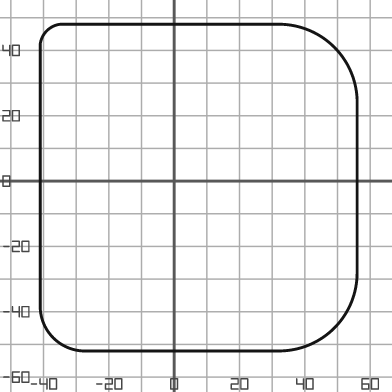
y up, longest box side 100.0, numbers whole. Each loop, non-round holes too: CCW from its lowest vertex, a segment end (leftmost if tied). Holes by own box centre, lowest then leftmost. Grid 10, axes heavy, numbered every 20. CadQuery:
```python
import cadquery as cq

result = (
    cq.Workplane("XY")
    .moveTo(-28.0, -52.0)
    .lineTo(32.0, -52.0)
    .threePointArc((49.0, -45.0), (56.0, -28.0))
    .lineTo(56.0, 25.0)
    .threePointArc((49.0, 41.0), (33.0, 48.0))
    .lineTo(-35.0, 48.0)
    .threePointArc((-39.0, 46.0), (-41.0, 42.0))
    .lineTo(-41.0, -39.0)
    .threePointArc((-37.0, -48.0), (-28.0, -52.0))
    .close()
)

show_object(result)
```